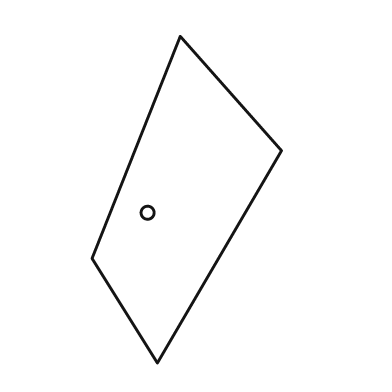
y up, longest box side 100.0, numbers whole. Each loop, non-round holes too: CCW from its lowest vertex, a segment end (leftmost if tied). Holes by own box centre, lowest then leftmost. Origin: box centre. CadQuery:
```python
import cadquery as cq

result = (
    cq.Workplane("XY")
    .moveTo(-9.0, -50.0)
    .lineTo(29.0, 15.0)
    .lineTo(-2.0, 50.0)
    .lineTo(-29.0, -18.0)
    .close()
    .moveTo(-12.0, -4.0)
    .circle(2.0)
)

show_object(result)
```